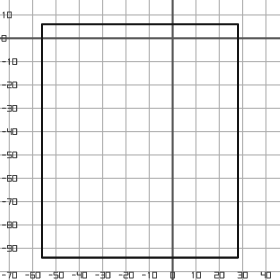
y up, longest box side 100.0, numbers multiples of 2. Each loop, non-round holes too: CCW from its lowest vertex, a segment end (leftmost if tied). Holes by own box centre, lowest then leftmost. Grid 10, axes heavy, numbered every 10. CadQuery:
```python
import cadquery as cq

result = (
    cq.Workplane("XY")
    .moveTo(-56.0, -94.0)
    .lineTo(28.0, -94.0)
    .lineTo(28.0, 6.0)
    .lineTo(-56.0, 6.0)
    .close()
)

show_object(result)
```